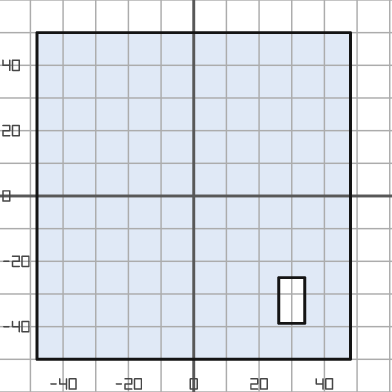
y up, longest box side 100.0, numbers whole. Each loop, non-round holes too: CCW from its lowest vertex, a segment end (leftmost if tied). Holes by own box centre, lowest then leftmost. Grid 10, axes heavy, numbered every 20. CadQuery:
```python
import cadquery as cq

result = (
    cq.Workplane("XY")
    .moveTo(-48.0, -50.0)
    .lineTo(48.0, -50.0)
    .lineTo(48.0, 50.0)
    .lineTo(-48.0, 50.0)
    .close()
    .moveTo(26.0, -39.0)
    .lineTo(34.0, -39.0)
    .lineTo(34.0, -25.0)
    .lineTo(26.0, -25.0)
    .close()
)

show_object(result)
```